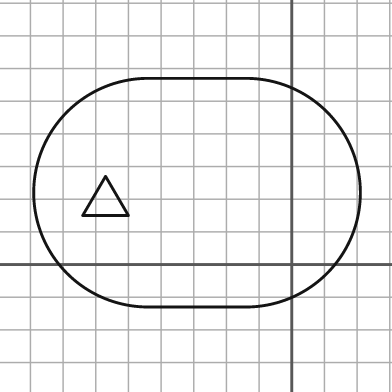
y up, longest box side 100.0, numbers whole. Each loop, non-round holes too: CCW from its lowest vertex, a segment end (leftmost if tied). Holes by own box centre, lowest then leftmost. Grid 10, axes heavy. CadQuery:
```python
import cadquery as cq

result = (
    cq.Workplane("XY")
    .moveTo(-44.0, -13.0)
    .lineTo(-14.0, -13.0)
    .threePointArc((21.0, 22.0), (-14.0, 57.0))
    .lineTo(-44.0, 57.0)
    .threePointArc((-79.0, 22.0), (-44.0, -13.0))
    .close()
    .moveTo(-64.0, 15.0)
    .lineTo(-50.0, 15.0)
    .lineTo(-57.0, 27.0)
    .close()
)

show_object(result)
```